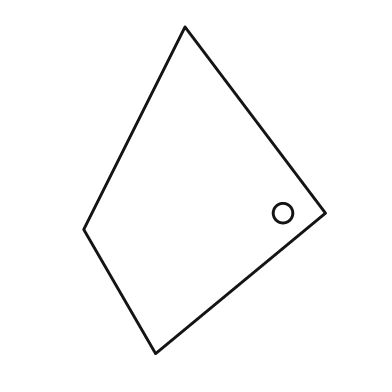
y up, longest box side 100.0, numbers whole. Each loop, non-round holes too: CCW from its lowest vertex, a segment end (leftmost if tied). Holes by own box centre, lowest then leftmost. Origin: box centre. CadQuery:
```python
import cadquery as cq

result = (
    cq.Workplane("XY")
    .moveTo(-15.0, -50.0)
    .lineTo(37.0, -7.0)
    .lineTo(-6.0, 50.0)
    .lineTo(-37.0, -12.0)
    .close()
    .moveTo(24.0, -7.0)
    .circle(3.0)
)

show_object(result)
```